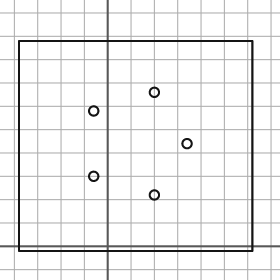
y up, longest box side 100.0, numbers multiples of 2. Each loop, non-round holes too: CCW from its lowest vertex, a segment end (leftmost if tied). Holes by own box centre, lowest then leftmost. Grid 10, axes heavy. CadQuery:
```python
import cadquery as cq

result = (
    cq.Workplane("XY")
    .moveTo(-38.0, -2.0)
    .lineTo(62.0, -2.0)
    .lineTo(62.0, 88.0)
    .lineTo(-38.0, 88.0)
    .close()
    .moveTo(20.0, 22.0)
    .circle(2.0)
    .moveTo(-6.0, 30.0)
    .circle(2.0)
    .moveTo(34.0, 44.0)
    .circle(2.0)
    .moveTo(-6.0, 58.0)
    .circle(2.0)
    .moveTo(20.0, 66.0)
    .circle(2.0)
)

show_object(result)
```